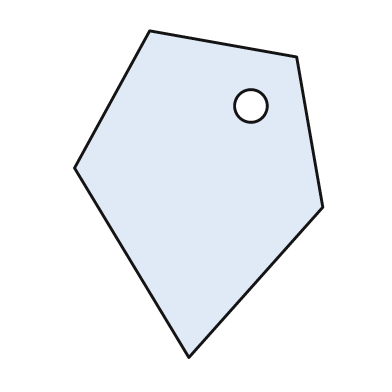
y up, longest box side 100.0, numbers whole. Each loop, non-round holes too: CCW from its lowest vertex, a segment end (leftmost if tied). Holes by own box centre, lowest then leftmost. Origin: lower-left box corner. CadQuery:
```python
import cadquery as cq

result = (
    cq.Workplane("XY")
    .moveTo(35.0, 0.0)
    .lineTo(76.0, 46.0)
    .lineTo(68.0, 92.0)
    .lineTo(23.0, 100.0)
    .lineTo(0.0, 58.0)
    .close()
    .moveTo(54.0, 77.0)
    .circle(5.0)
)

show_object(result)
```